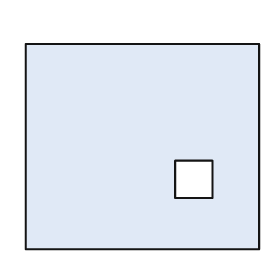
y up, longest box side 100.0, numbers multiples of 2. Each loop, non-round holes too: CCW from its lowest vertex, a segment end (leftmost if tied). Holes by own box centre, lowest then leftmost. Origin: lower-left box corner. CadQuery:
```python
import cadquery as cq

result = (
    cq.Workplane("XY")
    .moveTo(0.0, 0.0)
    .lineTo(100.0, 0.0)
    .lineTo(100.0, 88.0)
    .lineTo(0.0, 88.0)
    .close()
    .moveTo(64.0, 22.0)
    .lineTo(80.0, 22.0)
    .lineTo(80.0, 38.0)
    .lineTo(64.0, 38.0)
    .close()
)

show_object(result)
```